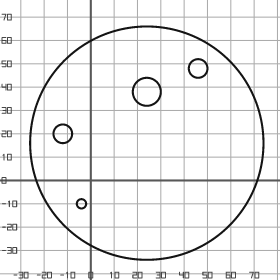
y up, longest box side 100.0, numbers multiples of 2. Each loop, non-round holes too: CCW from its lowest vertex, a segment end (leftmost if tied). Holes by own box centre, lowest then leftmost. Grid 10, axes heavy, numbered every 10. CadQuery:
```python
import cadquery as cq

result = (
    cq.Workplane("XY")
    .moveTo(24.0, 16.0)
    .circle(50.0)
    .moveTo(-4.0, -10.0)
    .circle(2.0)
    .moveTo(-12.0, 20.0)
    .circle(4.0)
    .moveTo(24.0, 38.0)
    .circle(6.0)
    .moveTo(46.0, 48.0)
    .circle(4.0)
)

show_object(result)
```